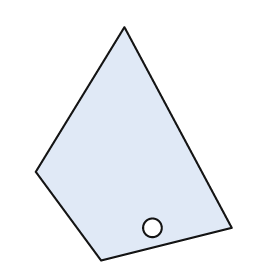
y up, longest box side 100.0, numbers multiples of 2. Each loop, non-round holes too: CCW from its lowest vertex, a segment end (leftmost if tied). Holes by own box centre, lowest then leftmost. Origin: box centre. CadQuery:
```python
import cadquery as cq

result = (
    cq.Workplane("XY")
    .moveTo(-14.0, -50.0)
    .lineTo(42.0, -36.0)
    .lineTo(-4.0, 50.0)
    .lineTo(-42.0, -12.0)
    .close()
    .moveTo(8.0, -36.0)
    .circle(4.0)
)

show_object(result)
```